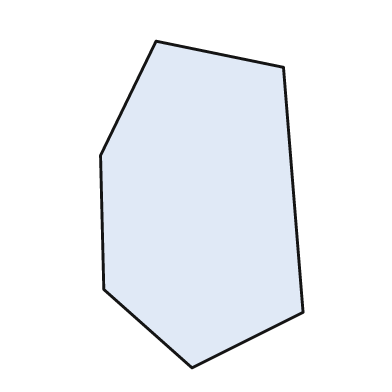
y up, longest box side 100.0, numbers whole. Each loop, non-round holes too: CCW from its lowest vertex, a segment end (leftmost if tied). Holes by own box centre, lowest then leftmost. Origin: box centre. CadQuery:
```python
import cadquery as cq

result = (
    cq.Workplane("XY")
    .moveTo(-3.0, -50.0)
    .lineTo(31.0, -33.0)
    .lineTo(25.0, 42.0)
    .lineTo(-14.0, 50.0)
    .lineTo(-31.0, 15.0)
    .lineTo(-30.0, -26.0)
    .close()
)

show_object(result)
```